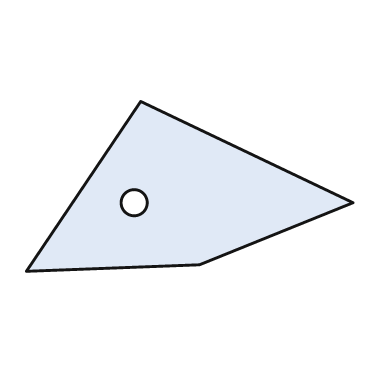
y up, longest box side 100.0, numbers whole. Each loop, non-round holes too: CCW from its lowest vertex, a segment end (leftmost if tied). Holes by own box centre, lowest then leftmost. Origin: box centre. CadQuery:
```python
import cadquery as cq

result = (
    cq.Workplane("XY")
    .moveTo(-50.0, -26.0)
    .lineTo(3.0, -24.0)
    .lineTo(50.0, -5.0)
    .lineTo(-15.0, 26.0)
    .close()
    .moveTo(-17.0, -5.0)
    .circle(4.0)
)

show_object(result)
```